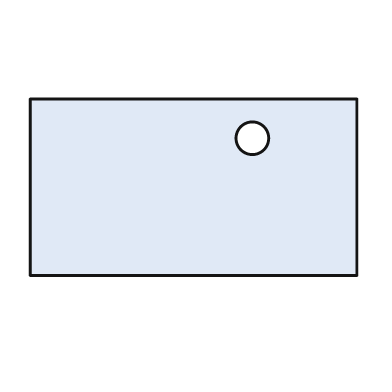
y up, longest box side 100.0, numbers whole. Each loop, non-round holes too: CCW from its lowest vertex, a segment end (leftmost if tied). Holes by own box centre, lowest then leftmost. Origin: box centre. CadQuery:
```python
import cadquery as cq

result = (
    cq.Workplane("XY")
    .moveTo(-50.0, -27.0)
    .lineTo(50.0, -27.0)
    .lineTo(50.0, 27.0)
    .lineTo(-50.0, 27.0)
    .close()
    .moveTo(18.0, 15.0)
    .circle(5.0)
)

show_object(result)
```